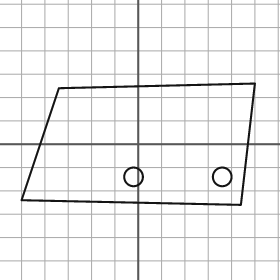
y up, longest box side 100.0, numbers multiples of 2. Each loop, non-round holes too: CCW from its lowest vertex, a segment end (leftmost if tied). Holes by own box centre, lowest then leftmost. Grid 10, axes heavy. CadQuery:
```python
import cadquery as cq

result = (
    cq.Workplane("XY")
    .moveTo(44.0, -26.0)
    .lineTo(50.0, 26.0)
    .lineTo(-34.0, 24.0)
    .lineTo(-50.0, -24.0)
    .close()
    .moveTo(-2.0, -14.0)
    .circle(4.0)
    .moveTo(36.0, -14.0)
    .circle(4.0)
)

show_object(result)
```